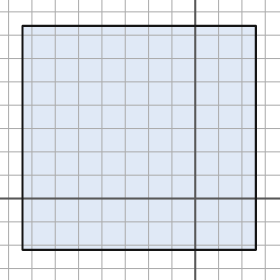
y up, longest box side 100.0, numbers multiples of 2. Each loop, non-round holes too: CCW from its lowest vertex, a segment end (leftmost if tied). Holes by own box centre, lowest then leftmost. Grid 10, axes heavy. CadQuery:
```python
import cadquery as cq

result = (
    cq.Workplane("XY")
    .moveTo(-74.0, -22.0)
    .lineTo(26.0, -22.0)
    .lineTo(26.0, 74.0)
    .lineTo(-74.0, 74.0)
    .close()
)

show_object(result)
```